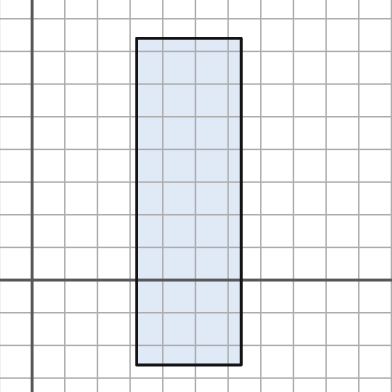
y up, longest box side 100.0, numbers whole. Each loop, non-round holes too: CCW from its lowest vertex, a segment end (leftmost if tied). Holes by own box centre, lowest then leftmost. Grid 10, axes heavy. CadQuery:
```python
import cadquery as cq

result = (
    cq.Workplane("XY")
    .moveTo(32.0, -26.0)
    .lineTo(64.0, -26.0)
    .lineTo(64.0, 74.0)
    .lineTo(32.0, 74.0)
    .close()
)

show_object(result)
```